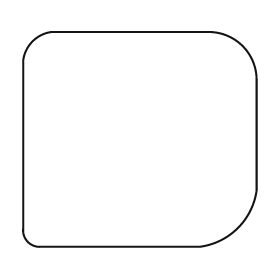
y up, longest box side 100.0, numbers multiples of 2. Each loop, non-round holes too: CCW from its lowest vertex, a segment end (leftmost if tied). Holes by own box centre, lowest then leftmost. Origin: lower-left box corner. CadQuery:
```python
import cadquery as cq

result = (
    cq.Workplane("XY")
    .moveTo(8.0, 0.0)
    .lineTo(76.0, 0.0)
    .threePointArc((92.0, 8.0), (100.0, 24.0))
    .lineTo(100.0, 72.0)
    .threePointArc((94.0, 86.0), (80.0, 92.0))
    .lineTo(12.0, 92.0)
    .threePointArc((4.0, 88.0), (0.0, 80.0))
    .lineTo(0.0, 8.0)
    .threePointArc((2.0, 2.0), (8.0, 0.0))
    .close()
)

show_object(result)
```